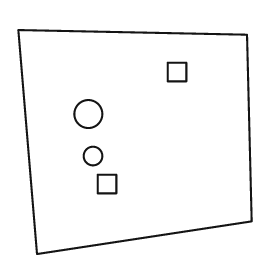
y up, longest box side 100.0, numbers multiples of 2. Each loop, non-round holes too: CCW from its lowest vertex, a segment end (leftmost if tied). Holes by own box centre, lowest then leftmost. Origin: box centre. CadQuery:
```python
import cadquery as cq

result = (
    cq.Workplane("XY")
    .moveTo(-42.0, -48.0)
    .lineTo(50.0, -34.0)
    .lineTo(48.0, 46.0)
    .lineTo(-50.0, 48.0)
    .close()
    .moveTo(-16.0, -22.0)
    .lineTo(-8.0, -22.0)
    .lineTo(-8.0, -14.0)
    .lineTo(-16.0, -14.0)
    .close()
    .moveTo(-18.0, -6.0)
    .circle(4.0)
    .moveTo(-20.0, 12.0)
    .circle(6.0)
    .moveTo(14.0, 26.0)
    .lineTo(22.0, 26.0)
    .lineTo(22.0, 34.0)
    .lineTo(14.0, 34.0)
    .close()
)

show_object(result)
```